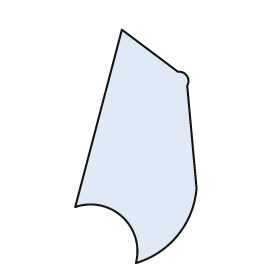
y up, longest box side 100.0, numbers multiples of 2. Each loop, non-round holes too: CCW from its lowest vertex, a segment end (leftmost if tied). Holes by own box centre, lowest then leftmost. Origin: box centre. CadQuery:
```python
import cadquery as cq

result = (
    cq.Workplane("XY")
    .moveTo(0.0, -50.0)
    .threePointArc((18.0, -38.0), (26.0, -18.0))
    .lineTo(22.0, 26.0)
    .threePointArc((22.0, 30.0), (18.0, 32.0))
    .lineTo(-6.0, 50.0)
    .lineTo(-26.0, -26.0)
    .threePointArc((-6.0, -30.0), (0.0, -50.0))
    .close()
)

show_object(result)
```